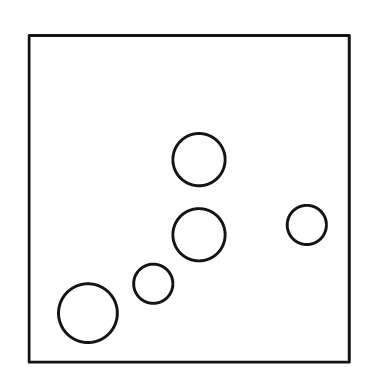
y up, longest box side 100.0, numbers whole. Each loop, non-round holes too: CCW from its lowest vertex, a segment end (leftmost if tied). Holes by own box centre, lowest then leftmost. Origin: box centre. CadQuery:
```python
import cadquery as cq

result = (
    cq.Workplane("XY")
    .moveTo(-49.0, -50.0)
    .lineTo(49.0, -50.0)
    .lineTo(49.0, 50.0)
    .lineTo(-49.0, 50.0)
    .close()
    .moveTo(-31.0, -35.0)
    .circle(9.0)
    .moveTo(-11.0, -26.0)
    .circle(6.0)
    .moveTo(3.0, -11.0)
    .circle(8.0)
    .moveTo(36.0, -8.0)
    .circle(6.0)
    .moveTo(3.0, 12.0)
    .circle(8.0)
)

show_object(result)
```